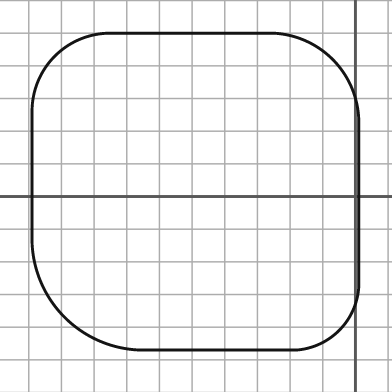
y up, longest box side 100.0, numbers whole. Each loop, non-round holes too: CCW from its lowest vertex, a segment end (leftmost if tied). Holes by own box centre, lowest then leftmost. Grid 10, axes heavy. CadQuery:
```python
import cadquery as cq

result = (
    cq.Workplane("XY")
    .moveTo(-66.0, -47.0)
    .lineTo(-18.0, -47.0)
    .threePointArc((-5.0, -41.0), (1.0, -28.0))
    .lineTo(1.0, 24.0)
    .threePointArc((-7.0, 42.0), (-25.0, 50.0))
    .lineTo(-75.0, 50.0)
    .threePointArc((-92.0, 43.0), (-99.0, 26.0))
    .lineTo(-99.0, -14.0)
    .threePointArc((-89.0, -37.0), (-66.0, -47.0))
    .close()
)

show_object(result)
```